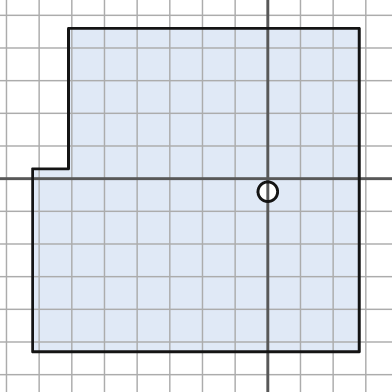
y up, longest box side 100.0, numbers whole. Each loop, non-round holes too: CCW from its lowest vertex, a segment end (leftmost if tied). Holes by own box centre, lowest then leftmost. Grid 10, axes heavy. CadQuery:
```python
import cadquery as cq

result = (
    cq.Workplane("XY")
    .moveTo(-72.0, -53.0)
    .lineTo(28.0, -53.0)
    .lineTo(28.0, 46.0)
    .lineTo(-61.0, 46.0)
    .lineTo(-61.0, 3.0)
    .lineTo(-72.0, 3.0)
    .close()
    .moveTo(0.0, -4.0)
    .circle(3.0)
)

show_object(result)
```